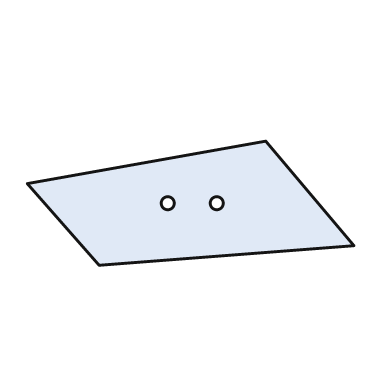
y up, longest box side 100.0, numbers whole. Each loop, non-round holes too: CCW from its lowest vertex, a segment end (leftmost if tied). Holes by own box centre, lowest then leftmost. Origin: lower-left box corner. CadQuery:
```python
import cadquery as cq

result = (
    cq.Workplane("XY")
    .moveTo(22.0, 0.0)
    .lineTo(100.0, 6.0)
    .lineTo(73.0, 38.0)
    .lineTo(0.0, 25.0)
    .close()
    .moveTo(43.0, 19.0)
    .circle(2.0)
    .moveTo(58.0, 19.0)
    .circle(2.0)
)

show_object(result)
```